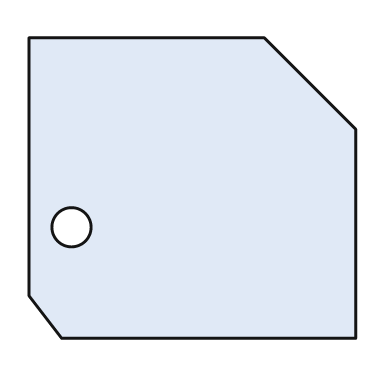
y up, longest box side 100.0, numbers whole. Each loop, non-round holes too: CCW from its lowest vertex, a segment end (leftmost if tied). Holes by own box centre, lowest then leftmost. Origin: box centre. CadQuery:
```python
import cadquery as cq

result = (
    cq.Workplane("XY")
    .moveTo(-40.0, -46.0)
    .lineTo(50.0, -46.0)
    .lineTo(50.0, 18.0)
    .lineTo(22.0, 46.0)
    .lineTo(-50.0, 46.0)
    .lineTo(-50.0, -33.0)
    .close()
    .moveTo(-37.0, -12.0)
    .circle(6.0)
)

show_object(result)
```